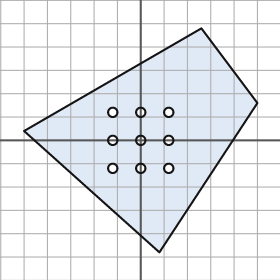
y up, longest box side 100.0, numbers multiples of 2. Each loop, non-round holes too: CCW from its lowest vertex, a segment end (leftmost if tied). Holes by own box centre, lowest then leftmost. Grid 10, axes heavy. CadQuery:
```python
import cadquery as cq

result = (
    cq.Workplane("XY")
    .moveTo(8.0, -48.0)
    .lineTo(50.0, 16.0)
    .lineTo(26.0, 48.0)
    .lineTo(-50.0, 4.0)
    .close()
    .moveTo(-12.0, -12.0)
    .circle(2.0)
    .moveTo(0.0, -12.0)
    .circle(2.0)
    .moveTo(12.0, -12.0)
    .circle(2.0)
    .moveTo(-12.0, 0.0)
    .circle(2.0)
    .moveTo(0.0, 0.0)
    .circle(2.0)
    .moveTo(12.0, 0.0)
    .circle(2.0)
    .moveTo(-12.0, 12.0)
    .circle(2.0)
    .moveTo(0.0, 12.0)
    .circle(2.0)
    .moveTo(12.0, 12.0)
    .circle(2.0)
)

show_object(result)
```